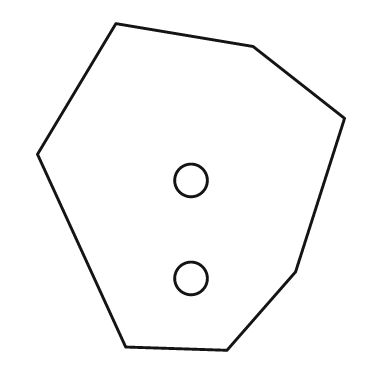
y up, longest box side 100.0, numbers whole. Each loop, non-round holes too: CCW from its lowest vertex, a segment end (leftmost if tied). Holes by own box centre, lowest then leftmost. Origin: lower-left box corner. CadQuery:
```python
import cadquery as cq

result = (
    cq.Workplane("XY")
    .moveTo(58.0, 0.0)
    .lineTo(79.0, 24.0)
    .lineTo(94.0, 71.0)
    .lineTo(66.0, 93.0)
    .lineTo(24.0, 100.0)
    .lineTo(0.0, 60.0)
    .lineTo(27.0, 1.0)
    .close()
    .moveTo(47.0, 22.0)
    .circle(5.0)
    .moveTo(47.0, 52.0)
    .circle(5.0)
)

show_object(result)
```